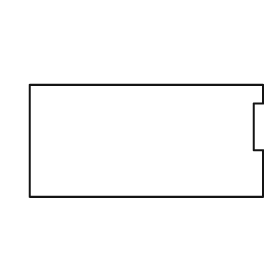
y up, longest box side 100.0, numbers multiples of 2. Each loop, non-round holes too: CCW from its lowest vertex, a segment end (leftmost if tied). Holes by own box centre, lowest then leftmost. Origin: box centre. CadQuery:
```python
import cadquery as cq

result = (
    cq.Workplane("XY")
    .moveTo(-50.0, -24.0)
    .lineTo(50.0, -24.0)
    .lineTo(50.0, -4.0)
    .lineTo(46.0, -4.0)
    .lineTo(46.0, 16.0)
    .lineTo(50.0, 16.0)
    .lineTo(50.0, 24.0)
    .lineTo(-50.0, 24.0)
    .close()
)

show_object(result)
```